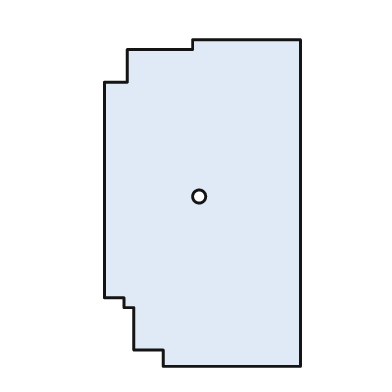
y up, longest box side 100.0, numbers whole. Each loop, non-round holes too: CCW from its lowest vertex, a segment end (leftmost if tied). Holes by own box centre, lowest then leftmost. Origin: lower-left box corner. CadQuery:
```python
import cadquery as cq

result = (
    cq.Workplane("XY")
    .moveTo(18.0, 0.0)
    .lineTo(60.0, 0.0)
    .lineTo(60.0, 100.0)
    .lineTo(27.0, 100.0)
    .lineTo(27.0, 97.0)
    .lineTo(7.0, 97.0)
    .lineTo(7.0, 87.0)
    .lineTo(0.0, 87.0)
    .lineTo(0.0, 21.0)
    .lineTo(6.0, 21.0)
    .lineTo(6.0, 18.0)
    .lineTo(9.0, 18.0)
    .lineTo(9.0, 5.0)
    .lineTo(18.0, 5.0)
    .close()
    .moveTo(29.0, 52.0)
    .circle(2.0)
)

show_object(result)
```